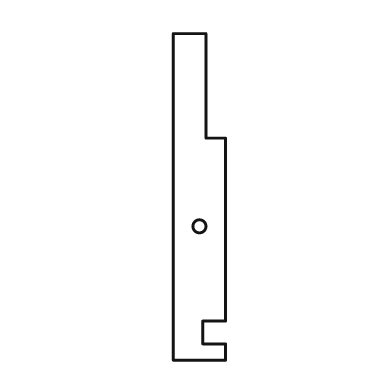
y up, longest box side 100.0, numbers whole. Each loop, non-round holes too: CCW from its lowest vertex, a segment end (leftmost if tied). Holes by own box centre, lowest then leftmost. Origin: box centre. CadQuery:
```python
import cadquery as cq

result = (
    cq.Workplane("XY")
    .moveTo(-8.0, -50.0)
    .lineTo(8.0, -50.0)
    .lineTo(8.0, -45.0)
    .lineTo(1.0, -45.0)
    .lineTo(1.0, -38.0)
    .lineTo(8.0, -38.0)
    .lineTo(8.0, 18.0)
    .lineTo(2.0, 18.0)
    .lineTo(2.0, 50.0)
    .lineTo(-8.0, 50.0)
    .close()
    .moveTo(0.0, -9.0)
    .circle(2.0)
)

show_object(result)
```